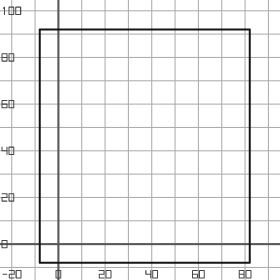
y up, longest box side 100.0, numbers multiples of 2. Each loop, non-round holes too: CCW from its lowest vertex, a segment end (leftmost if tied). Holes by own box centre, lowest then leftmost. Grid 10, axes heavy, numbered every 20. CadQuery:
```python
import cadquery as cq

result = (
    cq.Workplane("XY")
    .moveTo(-8.0, -8.0)
    .lineTo(82.0, -8.0)
    .lineTo(82.0, 92.0)
    .lineTo(-8.0, 92.0)
    .close()
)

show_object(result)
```